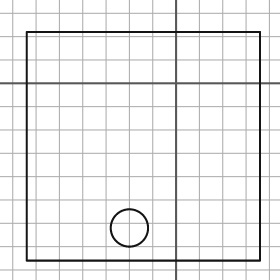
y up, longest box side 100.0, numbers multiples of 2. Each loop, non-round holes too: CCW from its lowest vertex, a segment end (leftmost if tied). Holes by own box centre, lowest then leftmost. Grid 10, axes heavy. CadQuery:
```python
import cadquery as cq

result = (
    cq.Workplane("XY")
    .moveTo(-64.0, -76.0)
    .lineTo(36.0, -76.0)
    .lineTo(36.0, 22.0)
    .lineTo(-64.0, 22.0)
    .close()
    .moveTo(-20.0, -62.0)
    .circle(8.0)
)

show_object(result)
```